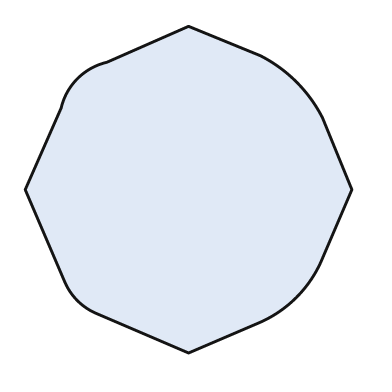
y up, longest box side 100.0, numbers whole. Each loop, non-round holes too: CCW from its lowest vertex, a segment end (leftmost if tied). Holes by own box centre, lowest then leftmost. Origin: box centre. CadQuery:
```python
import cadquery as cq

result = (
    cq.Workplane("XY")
    .moveTo(0.0, -50.0)
    .lineTo(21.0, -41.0)
    .threePointArc((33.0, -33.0), (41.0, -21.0))
    .lineTo(50.0, 0.0)
    .lineTo(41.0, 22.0)
    .threePointArc((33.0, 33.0), (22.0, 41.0))
    .lineTo(0.0, 50.0)
    .lineTo(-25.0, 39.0)
    .threePointArc((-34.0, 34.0), (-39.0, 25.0))
    .lineTo(-50.0, 0.0)
    .lineTo(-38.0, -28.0)
    .threePointArc((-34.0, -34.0), (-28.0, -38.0))
    .close()
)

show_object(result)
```